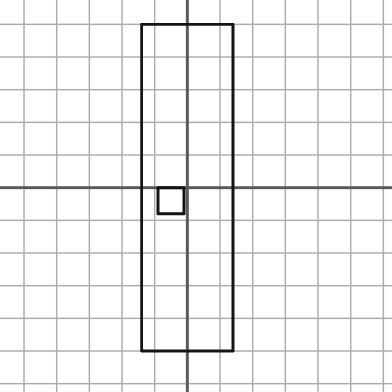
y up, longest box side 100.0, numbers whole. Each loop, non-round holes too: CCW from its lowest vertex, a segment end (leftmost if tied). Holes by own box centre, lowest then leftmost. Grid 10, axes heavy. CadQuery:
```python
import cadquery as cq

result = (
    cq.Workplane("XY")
    .moveTo(-14.0, -50.0)
    .lineTo(14.0, -50.0)
    .lineTo(14.0, 50.0)
    .lineTo(-14.0, 50.0)
    .close()
    .moveTo(-9.0, -8.0)
    .lineTo(-1.0, -8.0)
    .lineTo(-1.0, 0.0)
    .lineTo(-9.0, 0.0)
    .close()
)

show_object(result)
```